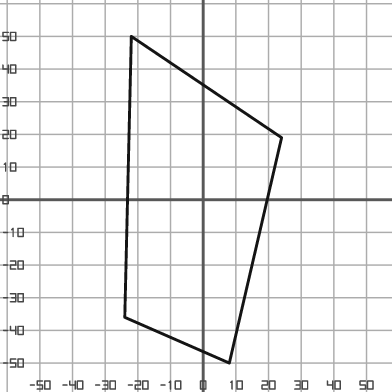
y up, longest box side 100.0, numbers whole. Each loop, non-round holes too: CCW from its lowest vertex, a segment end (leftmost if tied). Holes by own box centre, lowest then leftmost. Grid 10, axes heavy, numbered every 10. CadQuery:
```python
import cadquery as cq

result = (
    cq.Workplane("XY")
    .moveTo(8.0, -50.0)
    .lineTo(24.0, 19.0)
    .lineTo(-22.0, 50.0)
    .lineTo(-24.0, -36.0)
    .close()
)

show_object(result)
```